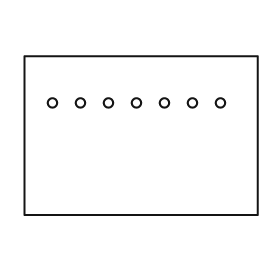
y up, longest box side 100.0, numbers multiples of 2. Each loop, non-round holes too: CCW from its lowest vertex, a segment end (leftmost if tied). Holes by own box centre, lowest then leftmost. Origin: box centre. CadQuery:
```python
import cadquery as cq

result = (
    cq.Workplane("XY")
    .moveTo(-50.0, -34.0)
    .lineTo(50.0, -34.0)
    .lineTo(50.0, 34.0)
    .lineTo(-50.0, 34.0)
    .close()
    .moveTo(-38.0, 14.0)
    .circle(2.0)
    .moveTo(-26.0, 14.0)
    .circle(2.0)
    .moveTo(-14.0, 14.0)
    .circle(2.0)
    .moveTo(-2.0, 14.0)
    .circle(2.0)
    .moveTo(10.0, 14.0)
    .circle(2.0)
    .moveTo(22.0, 14.0)
    .circle(2.0)
    .moveTo(34.0, 14.0)
    .circle(2.0)
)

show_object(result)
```